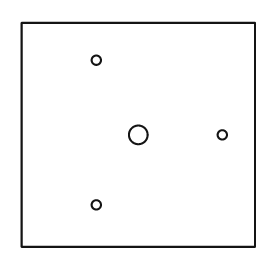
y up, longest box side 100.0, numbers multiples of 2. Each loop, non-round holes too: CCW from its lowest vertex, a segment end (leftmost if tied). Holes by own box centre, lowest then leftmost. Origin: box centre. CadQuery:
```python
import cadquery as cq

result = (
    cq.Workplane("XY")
    .moveTo(-50.0, -48.0)
    .lineTo(50.0, -48.0)
    .lineTo(50.0, 48.0)
    .lineTo(-50.0, 48.0)
    .close()
    .moveTo(-18.0, -30.0)
    .circle(2.0)
    .moveTo(0.0, 0.0)
    .circle(4.0)
    .moveTo(36.0, 0.0)
    .circle(2.0)
    .moveTo(-18.0, 32.0)
    .circle(2.0)
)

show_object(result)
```